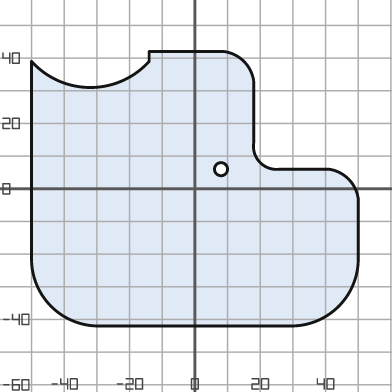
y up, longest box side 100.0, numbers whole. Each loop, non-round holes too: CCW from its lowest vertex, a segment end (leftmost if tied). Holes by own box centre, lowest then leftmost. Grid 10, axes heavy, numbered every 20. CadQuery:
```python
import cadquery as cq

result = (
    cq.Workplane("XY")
    .moveTo(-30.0, -42.0)
    .lineTo(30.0, -42.0)
    .threePointArc((44.0, -36.0), (50.0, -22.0))
    .lineTo(50.0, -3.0)
    .threePointArc((47.0, 3.0), (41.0, 6.0))
    .lineTo(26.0, 6.0)
    .threePointArc((20.0, 8.0), (18.0, 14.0))
    .lineTo(18.0, 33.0)
    .threePointArc((15.0, 39.0), (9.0, 42.0))
    .lineTo(-14.0, 42.0)
    .lineTo(-14.0, 39.0)
    .threePointArc((-32.0, 31.0), (-50.0, 39.0))
    .lineTo(-50.0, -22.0)
    .threePointArc((-44.0, -36.0), (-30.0, -42.0))
    .close()
    .moveTo(8.0, 6.0)
    .circle(2.0)
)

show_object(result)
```